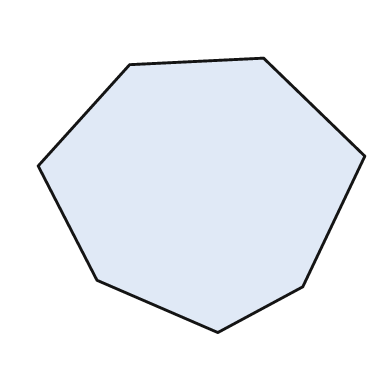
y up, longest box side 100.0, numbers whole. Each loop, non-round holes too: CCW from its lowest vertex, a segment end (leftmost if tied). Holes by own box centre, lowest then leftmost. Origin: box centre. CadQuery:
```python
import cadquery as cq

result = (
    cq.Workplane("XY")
    .moveTo(5.0, -42.0)
    .lineTo(31.0, -28.0)
    .lineTo(50.0, 12.0)
    .lineTo(19.0, 42.0)
    .lineTo(-22.0, 40.0)
    .lineTo(-50.0, 9.0)
    .lineTo(-32.0, -26.0)
    .close()
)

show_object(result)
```